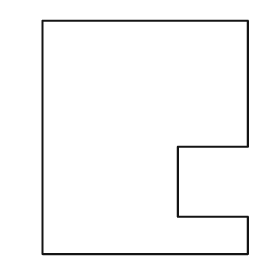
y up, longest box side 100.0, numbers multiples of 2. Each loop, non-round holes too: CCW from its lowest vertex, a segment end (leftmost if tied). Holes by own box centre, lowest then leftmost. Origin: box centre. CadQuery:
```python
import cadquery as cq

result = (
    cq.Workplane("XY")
    .moveTo(-44.0, -50.0)
    .lineTo(44.0, -50.0)
    .lineTo(44.0, -34.0)
    .lineTo(14.0, -34.0)
    .lineTo(14.0, -4.0)
    .lineTo(44.0, -4.0)
    .lineTo(44.0, 50.0)
    .lineTo(-44.0, 50.0)
    .close()
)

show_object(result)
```